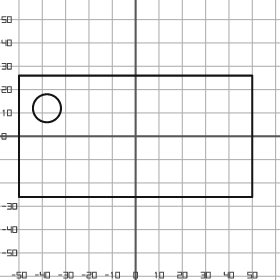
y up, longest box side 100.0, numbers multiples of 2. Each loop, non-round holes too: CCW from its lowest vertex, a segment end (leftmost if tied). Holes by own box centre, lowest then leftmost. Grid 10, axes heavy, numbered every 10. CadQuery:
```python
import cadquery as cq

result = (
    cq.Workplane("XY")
    .moveTo(-50.0, -26.0)
    .lineTo(50.0, -26.0)
    .lineTo(50.0, 26.0)
    .lineTo(-50.0, 26.0)
    .close()
    .moveTo(-38.0, 12.0)
    .circle(6.0)
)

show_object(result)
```